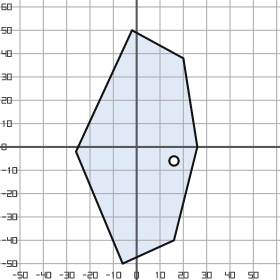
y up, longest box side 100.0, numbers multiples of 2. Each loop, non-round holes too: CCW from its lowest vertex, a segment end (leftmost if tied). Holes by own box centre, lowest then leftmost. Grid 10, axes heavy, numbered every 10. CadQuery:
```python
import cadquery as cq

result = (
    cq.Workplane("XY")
    .moveTo(-6.0, -50.0)
    .lineTo(16.0, -40.0)
    .lineTo(26.0, 0.0)
    .lineTo(20.0, 38.0)
    .lineTo(-2.0, 50.0)
    .lineTo(-26.0, -2.0)
    .close()
    .moveTo(16.0, -6.0)
    .circle(2.0)
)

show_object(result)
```